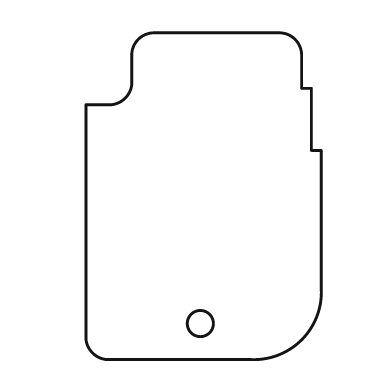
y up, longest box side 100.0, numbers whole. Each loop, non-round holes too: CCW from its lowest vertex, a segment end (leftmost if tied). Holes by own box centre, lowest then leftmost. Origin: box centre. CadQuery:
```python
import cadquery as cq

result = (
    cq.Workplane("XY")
    .moveTo(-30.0, -50.0)
    .lineTo(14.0, -50.0)
    .threePointArc((30.0, -44.0), (36.0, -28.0))
    .lineTo(36.0, 14.0)
    .lineTo(33.0, 14.0)
    .lineTo(33.0, 33.0)
    .lineTo(30.0, 33.0)
    .lineTo(30.0, 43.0)
    .threePointArc((28.0, 48.0), (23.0, 50.0))
    .lineTo(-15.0, 50.0)
    .threePointArc((-20.0, 48.0), (-22.0, 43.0))
    .lineTo(-22.0, 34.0)
    .threePointArc((-24.0, 30.0), (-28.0, 28.0))
    .lineTo(-36.0, 28.0)
    .lineTo(-36.0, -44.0)
    .threePointArc((-34.0, -48.0), (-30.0, -50.0))
    .close()
    .moveTo(-1.0, -39.0)
    .circle(4.0)
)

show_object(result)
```